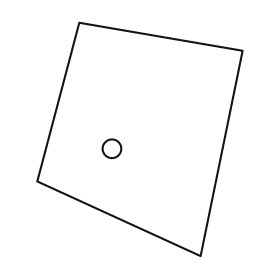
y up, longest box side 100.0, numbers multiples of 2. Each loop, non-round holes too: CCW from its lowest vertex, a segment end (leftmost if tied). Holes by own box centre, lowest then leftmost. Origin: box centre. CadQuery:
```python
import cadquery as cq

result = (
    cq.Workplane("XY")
    .moveTo(26.0, -50.0)
    .lineTo(44.0, 38.0)
    .lineTo(-26.0, 50.0)
    .lineTo(-44.0, -18.0)
    .close()
    .moveTo(-12.0, -4.0)
    .circle(4.0)
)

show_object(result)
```